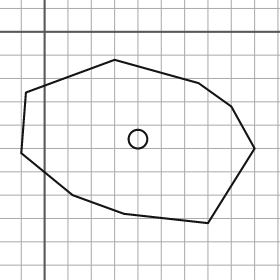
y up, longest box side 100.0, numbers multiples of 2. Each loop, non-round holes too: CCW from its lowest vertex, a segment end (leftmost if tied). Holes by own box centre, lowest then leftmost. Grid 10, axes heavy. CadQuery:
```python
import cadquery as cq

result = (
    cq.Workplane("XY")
    .moveTo(70.0, -82.0)
    .lineTo(90.0, -50.0)
    .lineTo(80.0, -32.0)
    .lineTo(66.0, -22.0)
    .lineTo(30.0, -12.0)
    .lineTo(-8.0, -26.0)
    .lineTo(-10.0, -52.0)
    .lineTo(12.0, -70.0)
    .lineTo(34.0, -78.0)
    .close()
    .moveTo(40.0, -46.0)
    .circle(4.0)
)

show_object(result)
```